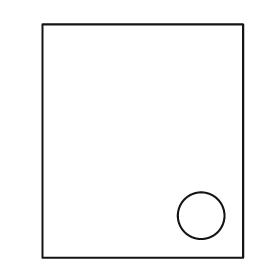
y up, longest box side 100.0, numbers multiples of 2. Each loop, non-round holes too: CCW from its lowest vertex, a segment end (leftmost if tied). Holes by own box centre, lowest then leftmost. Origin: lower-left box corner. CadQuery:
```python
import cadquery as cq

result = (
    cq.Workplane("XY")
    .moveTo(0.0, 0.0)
    .lineTo(86.0, 0.0)
    .lineTo(86.0, 100.0)
    .lineTo(0.0, 100.0)
    .close()
    .moveTo(68.0, 18.0)
    .circle(10.0)
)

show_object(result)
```